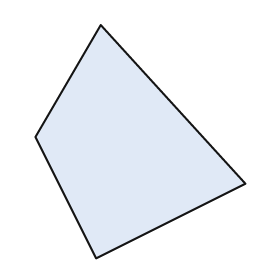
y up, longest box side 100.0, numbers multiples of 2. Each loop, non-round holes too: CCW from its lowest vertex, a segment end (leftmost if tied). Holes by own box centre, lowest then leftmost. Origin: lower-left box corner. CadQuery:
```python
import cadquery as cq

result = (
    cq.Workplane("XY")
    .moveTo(26.0, 0.0)
    .lineTo(90.0, 32.0)
    .lineTo(28.0, 100.0)
    .lineTo(0.0, 52.0)
    .close()
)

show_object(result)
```